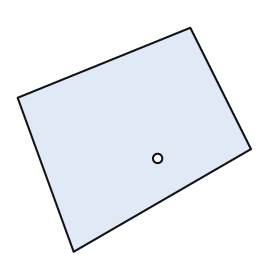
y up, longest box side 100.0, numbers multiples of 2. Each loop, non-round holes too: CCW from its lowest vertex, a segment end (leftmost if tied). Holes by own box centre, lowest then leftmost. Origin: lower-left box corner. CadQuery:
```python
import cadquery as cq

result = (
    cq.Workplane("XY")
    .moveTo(24.0, 0.0)
    .lineTo(100.0, 44.0)
    .lineTo(74.0, 96.0)
    .lineTo(0.0, 66.0)
    .close()
    .moveTo(60.0, 40.0)
    .circle(2.0)
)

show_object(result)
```